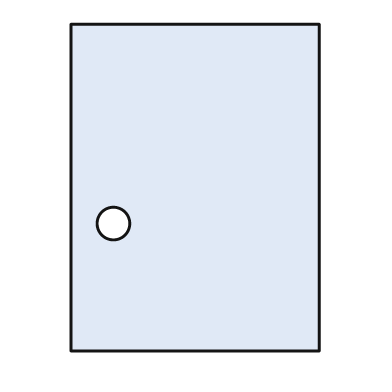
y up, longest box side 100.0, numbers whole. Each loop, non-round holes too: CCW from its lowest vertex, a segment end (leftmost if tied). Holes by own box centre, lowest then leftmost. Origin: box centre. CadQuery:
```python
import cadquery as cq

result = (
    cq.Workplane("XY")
    .moveTo(-38.0, -50.0)
    .lineTo(38.0, -50.0)
    .lineTo(38.0, 50.0)
    .lineTo(-38.0, 50.0)
    .close()
    .moveTo(-25.0, -11.0)
    .circle(5.0)
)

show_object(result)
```